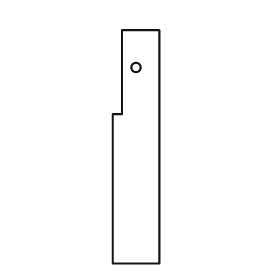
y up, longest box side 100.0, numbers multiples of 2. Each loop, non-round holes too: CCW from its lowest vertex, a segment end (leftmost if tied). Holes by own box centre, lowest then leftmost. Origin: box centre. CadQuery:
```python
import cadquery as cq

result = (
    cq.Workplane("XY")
    .moveTo(-10.0, -50.0)
    .lineTo(10.0, -50.0)
    .lineTo(10.0, 50.0)
    .lineTo(-6.0, 50.0)
    .lineTo(-6.0, 14.0)
    .lineTo(-10.0, 14.0)
    .close()
    .moveTo(0.0, 34.0)
    .circle(2.0)
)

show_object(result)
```